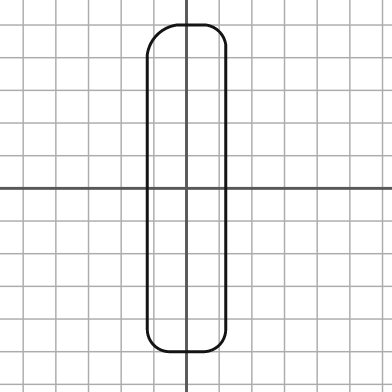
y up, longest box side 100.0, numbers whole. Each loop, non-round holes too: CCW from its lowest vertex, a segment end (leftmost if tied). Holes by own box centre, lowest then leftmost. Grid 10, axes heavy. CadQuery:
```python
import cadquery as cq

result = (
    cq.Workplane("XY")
    .moveTo(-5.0, -50.0)
    .lineTo(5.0, -50.0)
    .threePointArc((10.0, -48.0), (12.0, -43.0))
    .lineTo(12.0, 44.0)
    .threePointArc((10.0, 48.0), (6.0, 50.0))
    .lineTo(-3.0, 50.0)
    .threePointArc((-9.0, 47.0), (-12.0, 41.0))
    .lineTo(-12.0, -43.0)
    .threePointArc((-10.0, -48.0), (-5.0, -50.0))
    .close()
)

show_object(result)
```